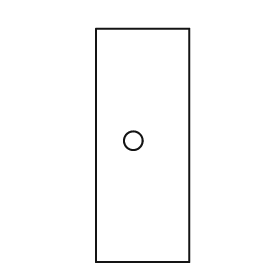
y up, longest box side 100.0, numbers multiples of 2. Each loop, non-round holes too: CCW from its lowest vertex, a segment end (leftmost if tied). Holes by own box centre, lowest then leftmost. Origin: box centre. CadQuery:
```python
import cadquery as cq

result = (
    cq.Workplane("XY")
    .moveTo(-20.0, -50.0)
    .lineTo(20.0, -50.0)
    .lineTo(20.0, 50.0)
    .lineTo(-20.0, 50.0)
    .close()
    .moveTo(-4.0, 2.0)
    .circle(4.0)
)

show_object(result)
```